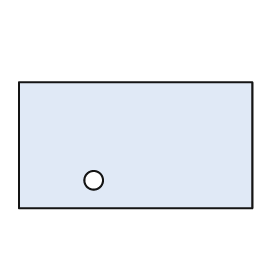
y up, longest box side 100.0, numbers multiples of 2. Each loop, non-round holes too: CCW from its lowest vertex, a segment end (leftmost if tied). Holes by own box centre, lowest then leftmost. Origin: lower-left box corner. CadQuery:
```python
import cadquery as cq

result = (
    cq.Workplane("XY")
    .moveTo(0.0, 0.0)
    .lineTo(100.0, 0.0)
    .lineTo(100.0, 54.0)
    .lineTo(0.0, 54.0)
    .close()
    .moveTo(32.0, 12.0)
    .circle(4.0)
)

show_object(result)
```